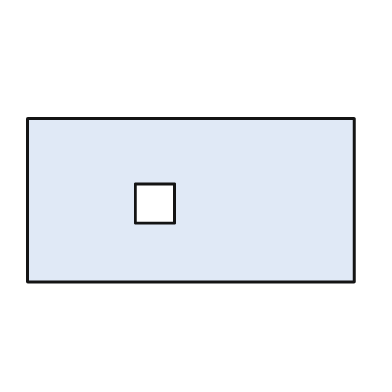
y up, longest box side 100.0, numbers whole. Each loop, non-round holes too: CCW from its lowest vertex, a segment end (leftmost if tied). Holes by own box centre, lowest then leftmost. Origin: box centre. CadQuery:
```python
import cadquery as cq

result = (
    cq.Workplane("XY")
    .moveTo(-50.0, -25.0)
    .lineTo(50.0, -25.0)
    .lineTo(50.0, 25.0)
    .lineTo(-50.0, 25.0)
    .close()
    .moveTo(-17.0, -7.0)
    .lineTo(-5.0, -7.0)
    .lineTo(-5.0, 5.0)
    .lineTo(-17.0, 5.0)
    .close()
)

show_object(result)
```